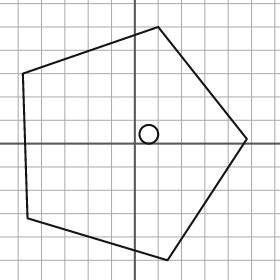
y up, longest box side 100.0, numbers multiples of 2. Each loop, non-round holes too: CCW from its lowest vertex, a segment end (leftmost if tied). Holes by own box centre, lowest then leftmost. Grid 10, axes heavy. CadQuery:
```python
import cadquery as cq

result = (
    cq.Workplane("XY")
    .moveTo(14.0, -50.0)
    .lineTo(48.0, 2.0)
    .lineTo(10.0, 50.0)
    .lineTo(-48.0, 30.0)
    .lineTo(-46.0, -32.0)
    .close()
    .moveTo(6.0, 4.0)
    .circle(4.0)
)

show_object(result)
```